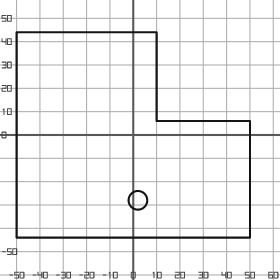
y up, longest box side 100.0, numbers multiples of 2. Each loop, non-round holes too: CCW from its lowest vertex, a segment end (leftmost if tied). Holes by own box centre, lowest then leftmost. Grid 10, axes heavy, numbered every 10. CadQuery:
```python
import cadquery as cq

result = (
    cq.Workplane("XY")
    .moveTo(-50.0, -44.0)
    .lineTo(50.0, -44.0)
    .lineTo(50.0, 6.0)
    .lineTo(10.0, 6.0)
    .lineTo(10.0, 44.0)
    .lineTo(-50.0, 44.0)
    .close()
    .moveTo(2.0, -28.0)
    .circle(4.0)
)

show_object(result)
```